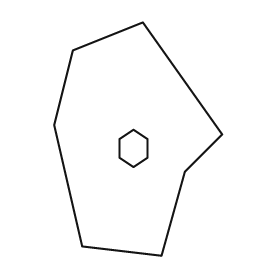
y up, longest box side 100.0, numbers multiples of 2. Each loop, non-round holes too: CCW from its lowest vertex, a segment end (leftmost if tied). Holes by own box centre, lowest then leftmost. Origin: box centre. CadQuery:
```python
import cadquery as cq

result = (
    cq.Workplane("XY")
    .moveTo(10.0, -50.0)
    .lineTo(20.0, -14.0)
    .lineTo(36.0, 2.0)
    .lineTo(2.0, 50.0)
    .lineTo(-28.0, 38.0)
    .lineTo(-36.0, 6.0)
    .lineTo(-24.0, -46.0)
    .close()
    .moveTo(-2.0, -12.0)
    .lineTo(4.0, -8.0)
    .lineTo(4.0, 0.0)
    .lineTo(-2.0, 4.0)
    .lineTo(-8.0, 0.0)
    .lineTo(-8.0, -8.0)
    .close()
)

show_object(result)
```